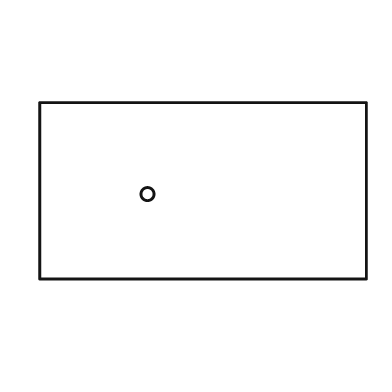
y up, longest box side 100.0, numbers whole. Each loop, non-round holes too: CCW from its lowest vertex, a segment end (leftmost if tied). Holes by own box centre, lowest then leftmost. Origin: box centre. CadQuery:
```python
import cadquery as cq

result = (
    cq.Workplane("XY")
    .moveTo(-50.0, -27.0)
    .lineTo(50.0, -27.0)
    .lineTo(50.0, 27.0)
    .lineTo(-50.0, 27.0)
    .close()
    .moveTo(-17.0, -1.0)
    .circle(2.0)
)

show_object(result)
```